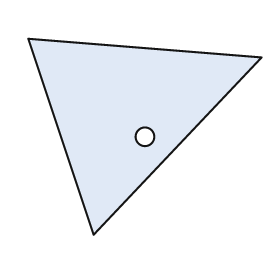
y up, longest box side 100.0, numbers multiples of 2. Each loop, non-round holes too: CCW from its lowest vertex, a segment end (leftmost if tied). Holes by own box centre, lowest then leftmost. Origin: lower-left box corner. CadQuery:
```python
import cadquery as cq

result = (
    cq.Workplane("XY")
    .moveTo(28.0, 0.0)
    .lineTo(100.0, 76.0)
    .lineTo(0.0, 84.0)
    .close()
    .moveTo(50.0, 42.0)
    .circle(4.0)
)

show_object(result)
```